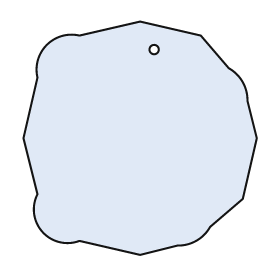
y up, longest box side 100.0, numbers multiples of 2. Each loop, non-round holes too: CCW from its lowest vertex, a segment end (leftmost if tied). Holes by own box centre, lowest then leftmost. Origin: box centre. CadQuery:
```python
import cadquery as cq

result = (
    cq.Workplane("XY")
    .moveTo(0.0, -50.0)
    .lineTo(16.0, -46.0)
    .threePointArc((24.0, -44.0), (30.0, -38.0))
    .lineTo(44.0, -26.0)
    .lineTo(50.0, 0.0)
    .lineTo(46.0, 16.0)
    .threePointArc((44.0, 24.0), (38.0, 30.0))
    .lineTo(26.0, 44.0)
    .lineTo(0.0, 50.0)
    .lineTo(-26.0, 44.0)
    .threePointArc((-40.0, 40.0), (-44.0, 26.0))
    .lineTo(-50.0, 0.0)
    .lineTo(-44.0, -24.0)
    .threePointArc((-42.0, -40.0), (-26.0, -44.0))
    .close()
    .moveTo(6.0, 38.0)
    .circle(2.0)
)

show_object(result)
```